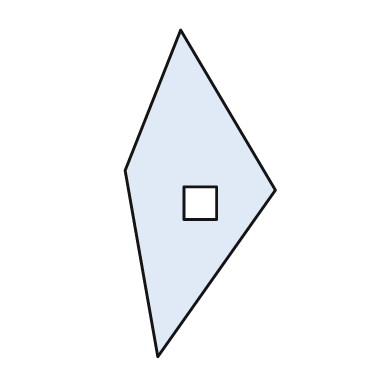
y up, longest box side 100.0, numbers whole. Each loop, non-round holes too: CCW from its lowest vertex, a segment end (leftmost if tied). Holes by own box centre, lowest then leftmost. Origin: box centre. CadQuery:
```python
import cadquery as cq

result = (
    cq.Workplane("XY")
    .moveTo(-13.0, -50.0)
    .lineTo(23.0, 1.0)
    .lineTo(-6.0, 50.0)
    .lineTo(-23.0, 7.0)
    .close()
    .moveTo(-5.0, -8.0)
    .lineTo(5.0, -8.0)
    .lineTo(5.0, 2.0)
    .lineTo(-5.0, 2.0)
    .close()
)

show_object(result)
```